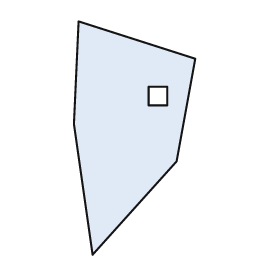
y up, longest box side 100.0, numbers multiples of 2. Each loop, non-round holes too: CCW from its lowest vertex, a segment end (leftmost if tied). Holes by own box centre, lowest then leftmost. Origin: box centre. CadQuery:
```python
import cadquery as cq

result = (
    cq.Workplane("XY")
    .moveTo(-18.0, -50.0)
    .lineTo(18.0, -10.0)
    .lineTo(26.0, 34.0)
    .lineTo(-24.0, 50.0)
    .lineTo(-26.0, 6.0)
    .close()
    .moveTo(6.0, 14.0)
    .lineTo(14.0, 14.0)
    .lineTo(14.0, 22.0)
    .lineTo(6.0, 22.0)
    .close()
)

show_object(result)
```